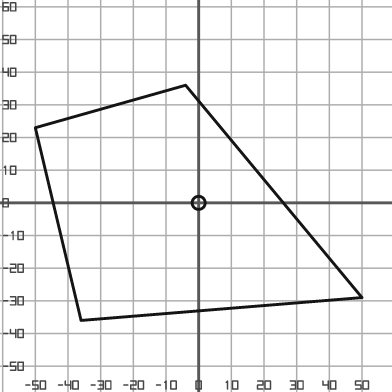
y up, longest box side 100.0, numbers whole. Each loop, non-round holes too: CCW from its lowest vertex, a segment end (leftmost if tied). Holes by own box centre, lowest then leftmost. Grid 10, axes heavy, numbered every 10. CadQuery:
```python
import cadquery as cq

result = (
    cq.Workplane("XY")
    .moveTo(-36.0, -36.0)
    .lineTo(50.0, -29.0)
    .lineTo(-4.0, 36.0)
    .lineTo(-50.0, 23.0)
    .close()
    .moveTo(0.0, 0.0)
    .circle(2.0)
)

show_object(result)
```